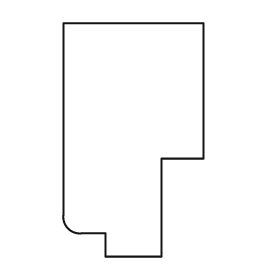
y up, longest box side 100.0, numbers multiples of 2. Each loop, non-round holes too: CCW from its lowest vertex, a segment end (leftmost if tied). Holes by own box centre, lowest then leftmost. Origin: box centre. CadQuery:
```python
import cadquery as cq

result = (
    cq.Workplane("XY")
    .moveTo(-12.0, -50.0)
    .lineTo(12.0, -50.0)
    .lineTo(12.0, -8.0)
    .lineTo(30.0, -8.0)
    .lineTo(30.0, 50.0)
    .lineTo(-30.0, 50.0)
    .lineTo(-30.0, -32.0)
    .threePointArc((-28.0, -38.0), (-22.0, -40.0))
    .lineTo(-12.0, -40.0)
    .close()
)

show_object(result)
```